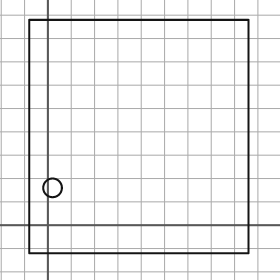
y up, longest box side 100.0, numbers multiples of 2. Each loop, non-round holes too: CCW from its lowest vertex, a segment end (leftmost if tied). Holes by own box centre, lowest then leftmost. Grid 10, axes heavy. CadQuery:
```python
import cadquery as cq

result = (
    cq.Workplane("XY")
    .moveTo(-8.0, -12.0)
    .lineTo(86.0, -12.0)
    .lineTo(86.0, 88.0)
    .lineTo(-8.0, 88.0)
    .close()
    .moveTo(2.0, 16.0)
    .circle(4.0)
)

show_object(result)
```